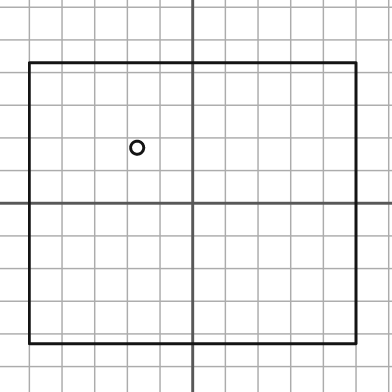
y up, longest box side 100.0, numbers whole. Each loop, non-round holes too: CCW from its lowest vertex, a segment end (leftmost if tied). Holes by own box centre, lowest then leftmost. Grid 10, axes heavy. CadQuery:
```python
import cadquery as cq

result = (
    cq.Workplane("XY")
    .moveTo(-50.0, -43.0)
    .lineTo(50.0, -43.0)
    .lineTo(50.0, 43.0)
    .lineTo(-50.0, 43.0)
    .close()
    .moveTo(-17.0, 17.0)
    .circle(2.0)
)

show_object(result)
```